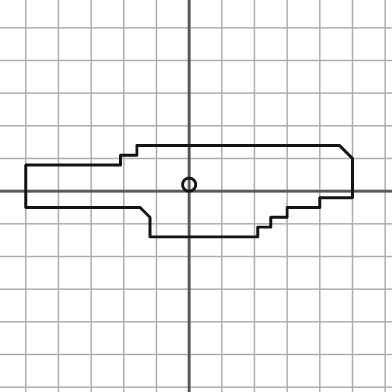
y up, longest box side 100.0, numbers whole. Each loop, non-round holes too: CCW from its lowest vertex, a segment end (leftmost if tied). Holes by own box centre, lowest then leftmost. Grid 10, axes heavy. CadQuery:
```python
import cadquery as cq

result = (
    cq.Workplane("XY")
    .moveTo(-12.0, -14.0)
    .lineTo(21.0, -14.0)
    .lineTo(21.0, -11.0)
    .lineTo(25.0, -11.0)
    .lineTo(25.0, -8.0)
    .lineTo(30.0, -8.0)
    .lineTo(30.0, -5.0)
    .lineTo(40.0, -5.0)
    .lineTo(40.0, -2.0)
    .lineTo(50.0, -2.0)
    .lineTo(50.0, 10.0)
    .lineTo(46.0, 14.0)
    .lineTo(-16.0, 14.0)
    .lineTo(-16.0, 11.0)
    .lineTo(-21.0, 11.0)
    .lineTo(-21.0, 8.0)
    .lineTo(-50.0, 8.0)
    .lineTo(-50.0, -5.0)
    .lineTo(-15.0, -5.0)
    .lineTo(-12.0, -8.0)
    .close()
    .moveTo(0.0, 2.0)
    .circle(2.0)
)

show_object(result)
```